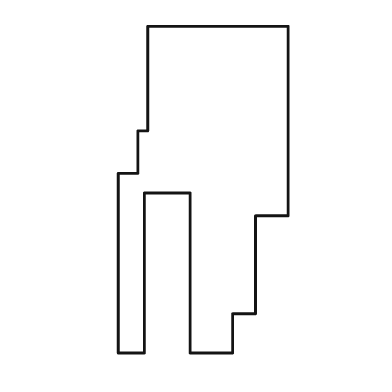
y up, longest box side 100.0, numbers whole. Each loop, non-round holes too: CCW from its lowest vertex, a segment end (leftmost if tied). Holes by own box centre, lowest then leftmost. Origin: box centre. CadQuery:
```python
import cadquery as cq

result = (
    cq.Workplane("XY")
    .moveTo(-26.0, -50.0)
    .lineTo(-18.0, -50.0)
    .lineTo(-18.0, -1.0)
    .lineTo(-4.0, -1.0)
    .lineTo(-4.0, -50.0)
    .lineTo(9.0, -50.0)
    .lineTo(9.0, -38.0)
    .lineTo(16.0, -38.0)
    .lineTo(16.0, -8.0)
    .lineTo(26.0, -8.0)
    .lineTo(26.0, 50.0)
    .lineTo(-17.0, 50.0)
    .lineTo(-17.0, 18.0)
    .lineTo(-20.0, 18.0)
    .lineTo(-20.0, 5.0)
    .lineTo(-26.0, 5.0)
    .close()
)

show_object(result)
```